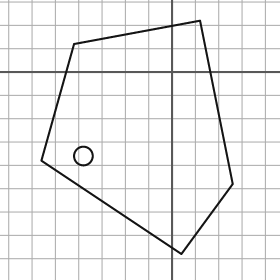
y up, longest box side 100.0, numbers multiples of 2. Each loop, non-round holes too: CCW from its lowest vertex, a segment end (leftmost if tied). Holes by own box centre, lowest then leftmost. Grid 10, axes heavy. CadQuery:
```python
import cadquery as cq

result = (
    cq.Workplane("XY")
    .moveTo(4.0, -78.0)
    .lineTo(26.0, -48.0)
    .lineTo(12.0, 22.0)
    .lineTo(-42.0, 12.0)
    .lineTo(-56.0, -38.0)
    .close()
    .moveTo(-38.0, -36.0)
    .circle(4.0)
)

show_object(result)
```